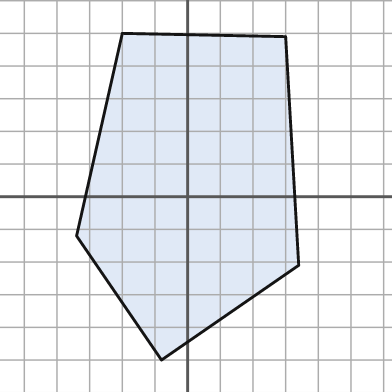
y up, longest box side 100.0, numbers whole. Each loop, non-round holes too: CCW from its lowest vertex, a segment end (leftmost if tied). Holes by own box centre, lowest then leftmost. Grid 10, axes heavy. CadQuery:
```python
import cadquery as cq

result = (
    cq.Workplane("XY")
    .moveTo(-8.0, -50.0)
    .lineTo(34.0, -21.0)
    .lineTo(30.0, 49.0)
    .lineTo(-20.0, 50.0)
    .lineTo(-34.0, -12.0)
    .close()
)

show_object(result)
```